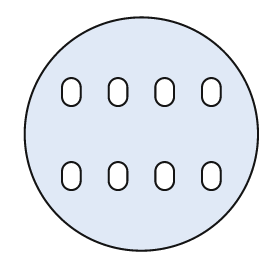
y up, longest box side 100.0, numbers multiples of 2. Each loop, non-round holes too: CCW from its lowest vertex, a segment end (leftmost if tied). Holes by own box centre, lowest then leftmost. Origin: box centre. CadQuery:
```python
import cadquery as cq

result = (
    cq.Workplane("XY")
    .moveTo(0.0, 0.0)
    .circle(50.0)
    .moveTo(-34.0, -20.0)
    .threePointArc((-30.0, -24.0), (-26.0, -20.0))
    .lineTo(-26.0, -16.0)
    .threePointArc((-30.0, -12.0), (-34.0, -16.0))
    .close()
    .moveTo(-14.0, -20.0)
    .threePointArc((-10.0, -24.0), (-6.0, -20.0))
    .lineTo(-6.0, -16.0)
    .threePointArc((-10.0, -12.0), (-14.0, -16.0))
    .close()
    .moveTo(6.0, -20.0)
    .threePointArc((10.0, -24.0), (14.0, -20.0))
    .lineTo(14.0, -16.0)
    .threePointArc((10.0, -12.0), (6.0, -16.0))
    .close()
    .moveTo(26.0, -20.0)
    .threePointArc((30.0, -24.0), (34.0, -20.0))
    .lineTo(34.0, -16.0)
    .threePointArc((30.0, -12.0), (26.0, -16.0))
    .close()
    .moveTo(-34.0, 16.0)
    .threePointArc((-30.0, 12.0), (-26.0, 16.0))
    .lineTo(-26.0, 20.0)
    .threePointArc((-30.0, 24.0), (-34.0, 20.0))
    .close()
    .moveTo(-14.0, 16.0)
    .threePointArc((-10.0, 12.0), (-6.0, 16.0))
    .lineTo(-6.0, 20.0)
    .threePointArc((-10.0, 24.0), (-14.0, 20.0))
    .close()
    .moveTo(6.0, 16.0)
    .threePointArc((10.0, 12.0), (14.0, 16.0))
    .lineTo(14.0, 20.0)
    .threePointArc((10.0, 24.0), (6.0, 20.0))
    .close()
    .moveTo(26.0, 16.0)
    .threePointArc((30.0, 12.0), (34.0, 16.0))
    .lineTo(34.0, 20.0)
    .threePointArc((30.0, 24.0), (26.0, 20.0))
    .close()
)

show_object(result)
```